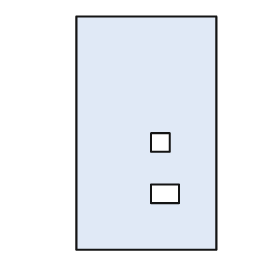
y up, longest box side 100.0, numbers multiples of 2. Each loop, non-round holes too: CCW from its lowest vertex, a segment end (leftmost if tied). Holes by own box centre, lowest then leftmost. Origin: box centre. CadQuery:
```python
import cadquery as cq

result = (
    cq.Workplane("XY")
    .moveTo(-30.0, -50.0)
    .lineTo(30.0, -50.0)
    .lineTo(30.0, 50.0)
    .lineTo(-30.0, 50.0)
    .close()
    .moveTo(2.0, -30.0)
    .lineTo(14.0, -30.0)
    .lineTo(14.0, -22.0)
    .lineTo(2.0, -22.0)
    .close()
    .moveTo(2.0, -8.0)
    .lineTo(10.0, -8.0)
    .lineTo(10.0, 0.0)
    .lineTo(2.0, 0.0)
    .close()
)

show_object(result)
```